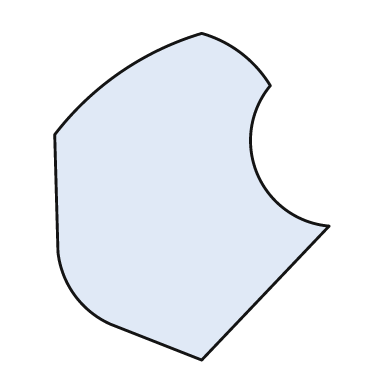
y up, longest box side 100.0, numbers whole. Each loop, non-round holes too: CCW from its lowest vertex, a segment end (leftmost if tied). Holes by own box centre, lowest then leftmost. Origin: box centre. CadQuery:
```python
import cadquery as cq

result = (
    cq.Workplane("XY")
    .moveTo(3.0, -50.0)
    .lineTo(42.0, -9.0)
    .threePointArc((20.0, 7.0), (24.0, 34.0))
    .threePointArc((15.0, 44.0), (3.0, 50.0))
    .threePointArc((-22.0, 38.0), (-42.0, 19.0))
    .lineTo(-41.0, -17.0)
    .threePointArc((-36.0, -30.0), (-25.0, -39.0))
    .close()
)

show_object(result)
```